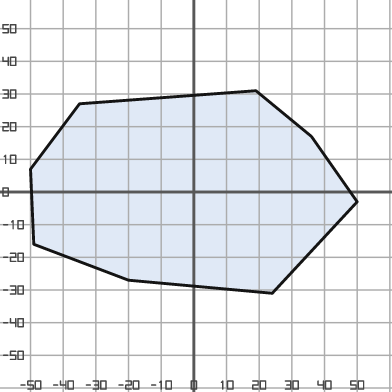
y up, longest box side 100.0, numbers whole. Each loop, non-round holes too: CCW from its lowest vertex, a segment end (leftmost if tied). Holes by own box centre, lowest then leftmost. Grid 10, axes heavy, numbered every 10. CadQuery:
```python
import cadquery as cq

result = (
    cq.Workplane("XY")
    .moveTo(24.0, -31.0)
    .lineTo(50.0, -3.0)
    .lineTo(36.0, 17.0)
    .lineTo(19.0, 31.0)
    .lineTo(-35.0, 27.0)
    .lineTo(-50.0, 7.0)
    .lineTo(-49.0, -16.0)
    .lineTo(-20.0, -27.0)
    .close()
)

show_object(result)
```